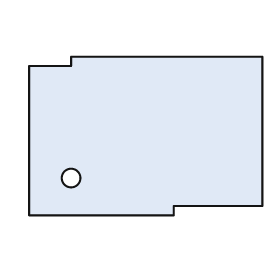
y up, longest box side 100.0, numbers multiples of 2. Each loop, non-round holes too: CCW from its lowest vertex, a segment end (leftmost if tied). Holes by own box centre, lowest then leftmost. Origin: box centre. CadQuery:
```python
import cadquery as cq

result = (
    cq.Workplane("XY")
    .moveTo(-50.0, -34.0)
    .lineTo(12.0, -34.0)
    .lineTo(12.0, -30.0)
    .lineTo(50.0, -30.0)
    .lineTo(50.0, 34.0)
    .lineTo(-32.0, 34.0)
    .lineTo(-32.0, 30.0)
    .lineTo(-50.0, 30.0)
    .close()
    .moveTo(-32.0, -18.0)
    .circle(4.0)
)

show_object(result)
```